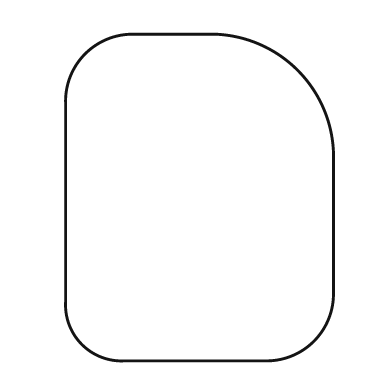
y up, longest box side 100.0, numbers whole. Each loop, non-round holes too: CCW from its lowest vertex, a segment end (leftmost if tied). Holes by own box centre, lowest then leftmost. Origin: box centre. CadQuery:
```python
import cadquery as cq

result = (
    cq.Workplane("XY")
    .moveTo(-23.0, -50.0)
    .lineTo(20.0, -50.0)
    .threePointArc((35.0, -44.0), (41.0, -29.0))
    .lineTo(41.0, 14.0)
    .threePointArc((30.0, 39.0), (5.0, 50.0))
    .lineTo(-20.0, 50.0)
    .threePointArc((-35.0, 44.0), (-41.0, 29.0))
    .lineTo(-41.0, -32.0)
    .threePointArc((-36.0, -45.0), (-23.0, -50.0))
    .close()
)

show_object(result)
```